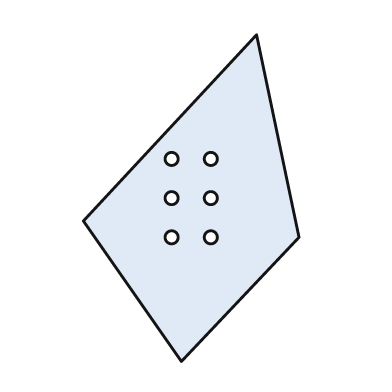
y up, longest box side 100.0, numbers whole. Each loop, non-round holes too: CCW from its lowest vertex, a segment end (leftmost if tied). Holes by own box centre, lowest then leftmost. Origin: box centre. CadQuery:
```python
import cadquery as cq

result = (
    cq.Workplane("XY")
    .moveTo(-3.0, -50.0)
    .lineTo(33.0, -12.0)
    .lineTo(20.0, 50.0)
    .lineTo(-33.0, -7.0)
    .close()
    .moveTo(-6.0, -12.0)
    .circle(2.0)
    .moveTo(6.0, -12.0)
    .circle(2.0)
    .moveTo(-6.0, 0.0)
    .circle(2.0)
    .moveTo(6.0, 0.0)
    .circle(2.0)
    .moveTo(-6.0, 12.0)
    .circle(2.0)
    .moveTo(6.0, 12.0)
    .circle(2.0)
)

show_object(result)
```